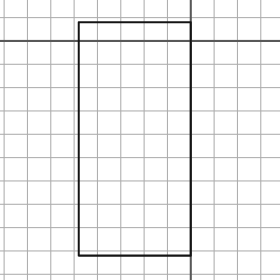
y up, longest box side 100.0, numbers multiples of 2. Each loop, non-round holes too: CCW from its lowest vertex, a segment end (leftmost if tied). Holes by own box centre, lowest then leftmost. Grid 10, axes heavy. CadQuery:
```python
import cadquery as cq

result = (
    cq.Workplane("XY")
    .moveTo(-48.0, -92.0)
    .lineTo(0.0, -92.0)
    .lineTo(0.0, 8.0)
    .lineTo(-48.0, 8.0)
    .close()
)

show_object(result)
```